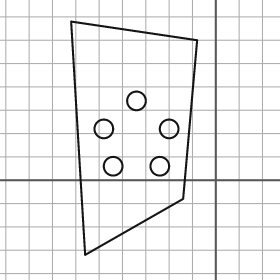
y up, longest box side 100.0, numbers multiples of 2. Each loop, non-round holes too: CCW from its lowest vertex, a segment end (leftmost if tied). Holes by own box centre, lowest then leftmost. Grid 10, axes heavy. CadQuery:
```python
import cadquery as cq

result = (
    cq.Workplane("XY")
    .moveTo(-56.0, -32.0)
    .lineTo(-14.0, -8.0)
    .lineTo(-8.0, 60.0)
    .lineTo(-62.0, 68.0)
    .close()
    .moveTo(-44.0, 6.0)
    .circle(4.0)
    .moveTo(-24.0, 6.0)
    .circle(4.0)
    .moveTo(-48.0, 22.0)
    .circle(4.0)
    .moveTo(-20.0, 22.0)
    .circle(4.0)
    .moveTo(-34.0, 34.0)
    .circle(4.0)
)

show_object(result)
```